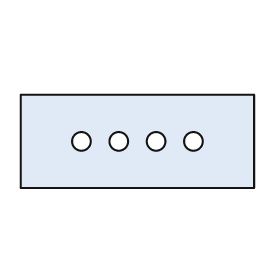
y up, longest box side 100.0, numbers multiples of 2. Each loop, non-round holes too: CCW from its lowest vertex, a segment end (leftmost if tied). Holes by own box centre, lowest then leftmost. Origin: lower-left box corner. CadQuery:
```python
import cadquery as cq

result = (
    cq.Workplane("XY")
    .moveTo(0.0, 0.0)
    .lineTo(100.0, 0.0)
    .lineTo(100.0, 40.0)
    .lineTo(0.0, 40.0)
    .close()
    .moveTo(26.0, 20.0)
    .circle(4.0)
    .moveTo(42.0, 20.0)
    .circle(4.0)
    .moveTo(58.0, 20.0)
    .circle(4.0)
    .moveTo(74.0, 20.0)
    .circle(4.0)
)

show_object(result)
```